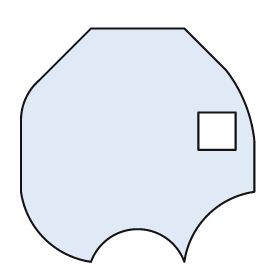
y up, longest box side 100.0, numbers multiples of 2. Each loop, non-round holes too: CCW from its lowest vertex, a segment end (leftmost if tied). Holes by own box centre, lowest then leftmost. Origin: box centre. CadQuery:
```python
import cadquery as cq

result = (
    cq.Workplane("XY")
    .moveTo(-20.0, -50.0)
    .threePointArc((0.0, -36.0), (20.0, -50.0))
    .threePointArc((30.0, -30.0), (50.0, -20.0))
    .lineTo(50.0, 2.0)
    .threePointArc((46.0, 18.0), (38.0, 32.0))
    .lineTo(20.0, 50.0)
    .lineTo(-20.0, 50.0)
    .lineTo(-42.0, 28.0)
    .threePointArc((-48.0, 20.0), (-50.0, 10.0))
    .lineTo(-50.0, -20.0)
    .threePointArc((-40.0, -40.0), (-20.0, -50.0))
    .close()
    .moveTo(26.0, -2.0)
    .lineTo(42.0, -2.0)
    .lineTo(42.0, 14.0)
    .lineTo(26.0, 14.0)
    .close()
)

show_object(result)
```